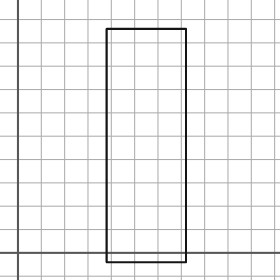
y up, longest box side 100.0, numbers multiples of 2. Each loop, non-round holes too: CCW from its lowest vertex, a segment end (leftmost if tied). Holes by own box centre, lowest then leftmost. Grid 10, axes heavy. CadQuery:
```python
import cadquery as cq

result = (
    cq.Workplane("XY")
    .moveTo(38.0, -4.0)
    .lineTo(72.0, -4.0)
    .lineTo(72.0, 96.0)
    .lineTo(38.0, 96.0)
    .close()
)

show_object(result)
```